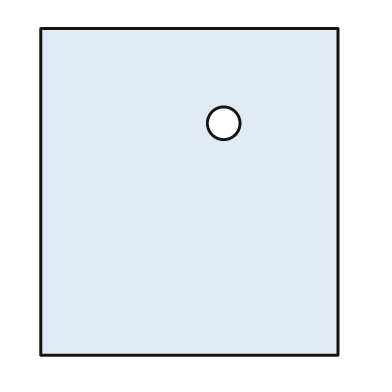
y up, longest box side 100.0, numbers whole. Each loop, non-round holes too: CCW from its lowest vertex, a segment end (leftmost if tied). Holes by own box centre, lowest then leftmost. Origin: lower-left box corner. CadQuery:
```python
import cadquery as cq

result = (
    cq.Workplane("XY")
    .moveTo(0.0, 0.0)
    .lineTo(91.0, 0.0)
    .lineTo(91.0, 100.0)
    .lineTo(0.0, 100.0)
    .close()
    .moveTo(56.0, 71.0)
    .circle(5.0)
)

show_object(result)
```